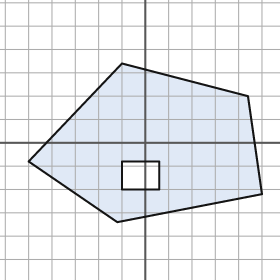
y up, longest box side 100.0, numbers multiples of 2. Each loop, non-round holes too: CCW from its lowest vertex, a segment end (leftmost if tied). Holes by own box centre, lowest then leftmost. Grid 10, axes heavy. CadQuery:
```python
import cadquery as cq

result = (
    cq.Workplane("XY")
    .moveTo(-12.0, -34.0)
    .lineTo(50.0, -22.0)
    .lineTo(44.0, 20.0)
    .lineTo(-10.0, 34.0)
    .lineTo(-50.0, -8.0)
    .close()
    .moveTo(-10.0, -20.0)
    .lineTo(6.0, -20.0)
    .lineTo(6.0, -8.0)
    .lineTo(-10.0, -8.0)
    .close()
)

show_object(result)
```